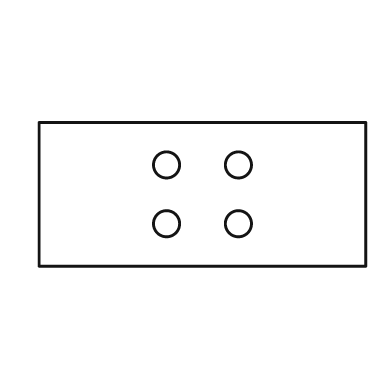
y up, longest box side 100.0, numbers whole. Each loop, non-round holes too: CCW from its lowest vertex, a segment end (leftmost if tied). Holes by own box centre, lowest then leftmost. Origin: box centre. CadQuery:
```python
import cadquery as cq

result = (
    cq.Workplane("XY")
    .moveTo(-50.0, -22.0)
    .lineTo(50.0, -22.0)
    .lineTo(50.0, 22.0)
    .lineTo(-50.0, 22.0)
    .close()
    .moveTo(-11.0, -9.0)
    .circle(4.0)
    .moveTo(11.0, -9.0)
    .circle(4.0)
    .moveTo(-11.0, 9.0)
    .circle(4.0)
    .moveTo(11.0, 9.0)
    .circle(4.0)
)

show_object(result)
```